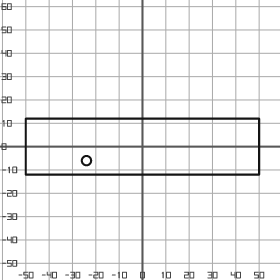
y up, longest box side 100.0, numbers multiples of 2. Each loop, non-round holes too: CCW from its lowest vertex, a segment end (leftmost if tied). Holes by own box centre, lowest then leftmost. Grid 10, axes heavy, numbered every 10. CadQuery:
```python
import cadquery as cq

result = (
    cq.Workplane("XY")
    .moveTo(-50.0, -12.0)
    .lineTo(50.0, -12.0)
    .lineTo(50.0, 12.0)
    .lineTo(-50.0, 12.0)
    .close()
    .moveTo(-24.0, -6.0)
    .circle(2.0)
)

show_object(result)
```